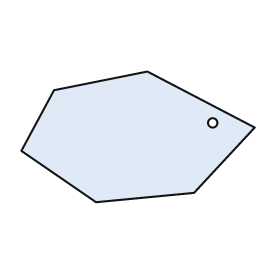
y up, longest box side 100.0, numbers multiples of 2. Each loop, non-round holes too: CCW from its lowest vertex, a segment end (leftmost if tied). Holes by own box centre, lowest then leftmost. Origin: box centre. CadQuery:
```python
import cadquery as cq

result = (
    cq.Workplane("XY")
    .moveTo(-18.0, -28.0)
    .lineTo(24.0, -24.0)
    .lineTo(50.0, 4.0)
    .lineTo(4.0, 28.0)
    .lineTo(-36.0, 20.0)
    .lineTo(-50.0, -6.0)
    .close()
    .moveTo(32.0, 6.0)
    .circle(2.0)
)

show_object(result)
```